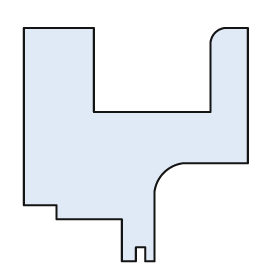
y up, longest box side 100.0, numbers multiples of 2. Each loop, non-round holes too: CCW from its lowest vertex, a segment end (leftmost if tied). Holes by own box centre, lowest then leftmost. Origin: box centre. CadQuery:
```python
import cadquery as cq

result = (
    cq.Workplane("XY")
    .moveTo(-6.0, -50.0)
    .lineTo(0.0, -50.0)
    .lineTo(0.0, -44.0)
    .lineTo(4.0, -44.0)
    .lineTo(4.0, -50.0)
    .lineTo(8.0, -50.0)
    .lineTo(8.0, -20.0)
    .threePointArc((12.0, -12.0), (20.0, -8.0))
    .lineTo(48.0, -8.0)
    .lineTo(48.0, 50.0)
    .lineTo(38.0, 50.0)
    .threePointArc((34.0, 48.0), (32.0, 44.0))
    .lineTo(32.0, 14.0)
    .lineTo(-18.0, 14.0)
    .lineTo(-18.0, 50.0)
    .lineTo(-48.0, 50.0)
    .lineTo(-48.0, -26.0)
    .lineTo(-34.0, -26.0)
    .lineTo(-34.0, -32.0)
    .lineTo(-6.0, -32.0)
    .close()
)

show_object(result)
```